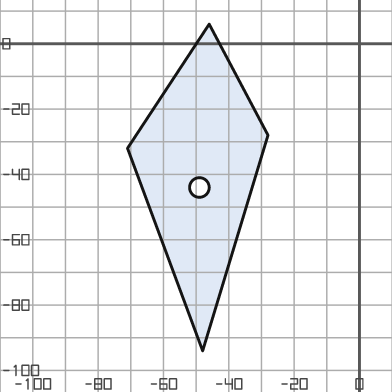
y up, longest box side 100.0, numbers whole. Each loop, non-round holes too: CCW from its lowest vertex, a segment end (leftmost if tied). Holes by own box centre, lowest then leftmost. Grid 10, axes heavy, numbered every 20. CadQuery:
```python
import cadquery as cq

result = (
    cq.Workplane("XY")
    .moveTo(-48.0, -94.0)
    .lineTo(-28.0, -28.0)
    .lineTo(-46.0, 6.0)
    .lineTo(-71.0, -32.0)
    .close()
    .moveTo(-49.0, -44.0)
    .circle(3.0)
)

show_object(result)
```